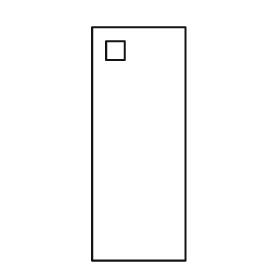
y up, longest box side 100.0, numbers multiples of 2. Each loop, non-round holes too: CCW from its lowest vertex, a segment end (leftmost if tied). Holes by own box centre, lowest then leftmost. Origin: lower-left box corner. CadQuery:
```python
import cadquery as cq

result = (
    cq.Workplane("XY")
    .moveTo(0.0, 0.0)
    .lineTo(40.0, 0.0)
    .lineTo(40.0, 100.0)
    .lineTo(0.0, 100.0)
    .close()
    .moveTo(6.0, 86.0)
    .lineTo(14.0, 86.0)
    .lineTo(14.0, 94.0)
    .lineTo(6.0, 94.0)
    .close()
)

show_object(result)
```